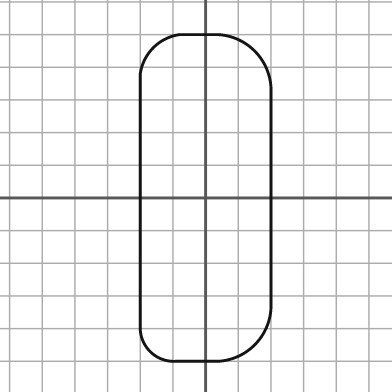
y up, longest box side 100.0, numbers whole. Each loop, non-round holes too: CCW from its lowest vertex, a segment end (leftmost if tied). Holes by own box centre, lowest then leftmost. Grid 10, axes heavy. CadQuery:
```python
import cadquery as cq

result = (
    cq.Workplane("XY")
    .moveTo(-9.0, -50.0)
    .lineTo(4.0, -50.0)
    .threePointArc((15.0, -45.0), (20.0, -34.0))
    .lineTo(20.0, 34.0)
    .threePointArc((15.0, 45.0), (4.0, 50.0))
    .lineTo(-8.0, 50.0)
    .threePointArc((-16.0, 46.0), (-20.0, 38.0))
    .lineTo(-20.0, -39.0)
    .threePointArc((-17.0, -47.0), (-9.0, -50.0))
    .close()
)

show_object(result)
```